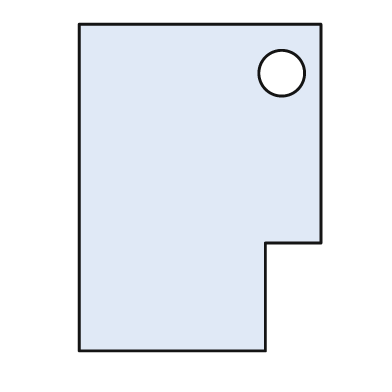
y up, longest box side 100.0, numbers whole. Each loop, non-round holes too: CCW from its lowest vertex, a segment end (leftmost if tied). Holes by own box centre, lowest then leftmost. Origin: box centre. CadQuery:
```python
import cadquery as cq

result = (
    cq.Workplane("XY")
    .moveTo(-37.0, -50.0)
    .lineTo(20.0, -50.0)
    .lineTo(20.0, -17.0)
    .lineTo(37.0, -17.0)
    .lineTo(37.0, 50.0)
    .lineTo(-37.0, 50.0)
    .close()
    .moveTo(25.0, 35.0)
    .circle(7.0)
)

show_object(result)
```